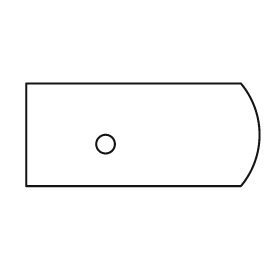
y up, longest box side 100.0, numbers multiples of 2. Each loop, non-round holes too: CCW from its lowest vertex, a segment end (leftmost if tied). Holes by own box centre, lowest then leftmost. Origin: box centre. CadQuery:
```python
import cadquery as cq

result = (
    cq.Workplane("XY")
    .moveTo(-50.0, -22.0)
    .lineTo(42.0, -22.0)
    .threePointArc((50.0, 0.0), (42.0, 22.0))
    .lineTo(-50.0, 22.0)
    .close()
    .moveTo(-16.0, -4.0)
    .circle(4.0)
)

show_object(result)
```